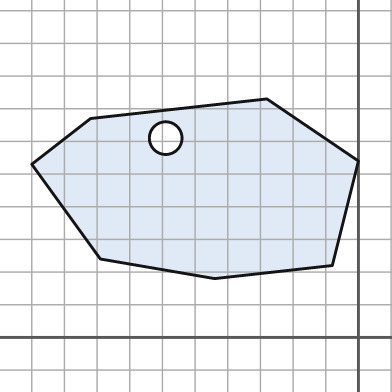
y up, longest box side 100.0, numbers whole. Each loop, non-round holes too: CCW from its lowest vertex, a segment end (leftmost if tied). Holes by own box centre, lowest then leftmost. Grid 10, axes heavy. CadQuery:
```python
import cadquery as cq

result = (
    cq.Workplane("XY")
    .moveTo(-44.0, 18.0)
    .lineTo(-8.0, 22.0)
    .lineTo(0.0, 54.0)
    .lineTo(-28.0, 73.0)
    .lineTo(-82.0, 67.0)
    .lineTo(-100.0, 53.0)
    .lineTo(-79.0, 24.0)
    .close()
    .moveTo(-59.0, 61.0)
    .circle(5.0)
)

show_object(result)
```